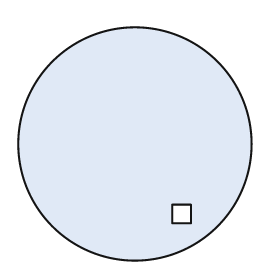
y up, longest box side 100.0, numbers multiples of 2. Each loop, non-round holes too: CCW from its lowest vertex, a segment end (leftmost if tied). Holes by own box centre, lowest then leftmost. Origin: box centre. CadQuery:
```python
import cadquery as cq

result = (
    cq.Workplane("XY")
    .moveTo(0.0, 0.0)
    .circle(50.0)
    .moveTo(16.0, -34.0)
    .lineTo(24.0, -34.0)
    .lineTo(24.0, -26.0)
    .lineTo(16.0, -26.0)
    .close()
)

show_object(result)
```